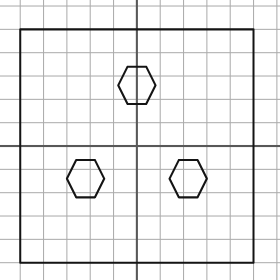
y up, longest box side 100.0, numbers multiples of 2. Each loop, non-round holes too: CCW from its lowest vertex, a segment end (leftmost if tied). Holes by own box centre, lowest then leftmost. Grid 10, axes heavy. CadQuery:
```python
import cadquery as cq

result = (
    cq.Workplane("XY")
    .moveTo(-50.0, -50.0)
    .lineTo(50.0, -50.0)
    .lineTo(50.0, 50.0)
    .lineTo(-50.0, 50.0)
    .close()
    .moveTo(-26.0, -22.0)
    .lineTo(-18.0, -22.0)
    .lineTo(-14.0, -14.0)
    .lineTo(-18.0, -6.0)
    .lineTo(-26.0, -6.0)
    .lineTo(-30.0, -14.0)
    .close()
    .moveTo(18.0, -22.0)
    .lineTo(26.0, -22.0)
    .lineTo(30.0, -14.0)
    .lineTo(26.0, -6.0)
    .lineTo(18.0, -6.0)
    .lineTo(14.0, -14.0)
    .close()
    .moveTo(-4.0, 18.0)
    .lineTo(4.0, 18.0)
    .lineTo(8.0, 26.0)
    .lineTo(4.0, 34.0)
    .lineTo(-4.0, 34.0)
    .lineTo(-8.0, 26.0)
    .close()
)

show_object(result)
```